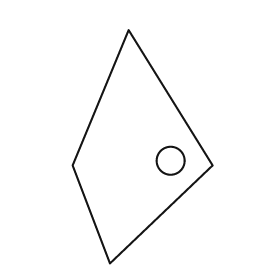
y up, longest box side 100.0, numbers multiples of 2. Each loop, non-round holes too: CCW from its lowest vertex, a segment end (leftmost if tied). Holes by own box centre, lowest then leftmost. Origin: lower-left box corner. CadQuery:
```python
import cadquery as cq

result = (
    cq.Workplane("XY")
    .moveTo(16.0, 0.0)
    .lineTo(60.0, 42.0)
    .lineTo(24.0, 100.0)
    .lineTo(0.0, 42.0)
    .close()
    .moveTo(42.0, 44.0)
    .circle(6.0)
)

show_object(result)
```